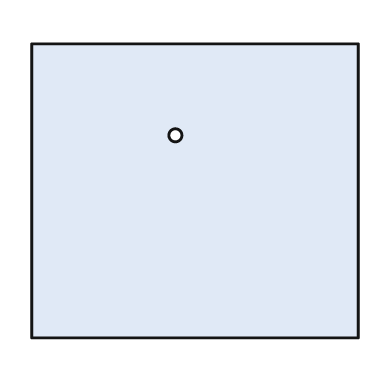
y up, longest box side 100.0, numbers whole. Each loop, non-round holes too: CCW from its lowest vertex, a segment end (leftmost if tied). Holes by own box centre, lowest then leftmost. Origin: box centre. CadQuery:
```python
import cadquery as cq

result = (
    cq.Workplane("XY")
    .moveTo(-50.0, -45.0)
    .lineTo(50.0, -45.0)
    .lineTo(50.0, 45.0)
    .lineTo(-50.0, 45.0)
    .close()
    .moveTo(-6.0, 17.0)
    .circle(2.0)
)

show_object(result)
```